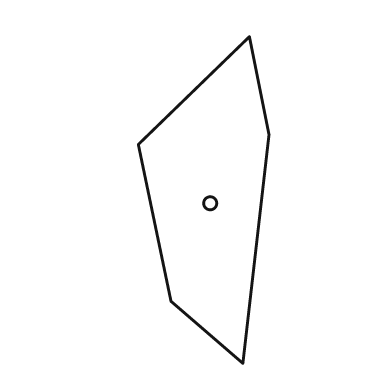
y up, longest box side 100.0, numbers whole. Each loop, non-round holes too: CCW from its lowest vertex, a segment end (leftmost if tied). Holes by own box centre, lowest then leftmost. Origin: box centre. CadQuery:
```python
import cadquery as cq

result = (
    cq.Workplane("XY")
    .moveTo(12.0, -50.0)
    .lineTo(20.0, 20.0)
    .lineTo(14.0, 50.0)
    .lineTo(-20.0, 17.0)
    .lineTo(-10.0, -31.0)
    .close()
    .moveTo(2.0, -1.0)
    .circle(2.0)
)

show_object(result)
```